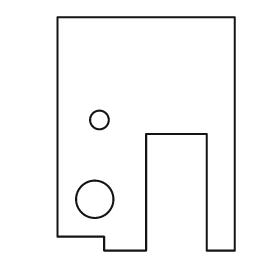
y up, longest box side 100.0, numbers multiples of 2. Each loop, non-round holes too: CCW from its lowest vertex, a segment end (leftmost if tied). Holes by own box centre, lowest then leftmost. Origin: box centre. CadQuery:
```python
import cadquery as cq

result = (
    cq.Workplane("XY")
    .moveTo(-18.0, -50.0)
    .lineTo(0.0, -50.0)
    .lineTo(0.0, 0.0)
    .lineTo(26.0, 0.0)
    .lineTo(26.0, -50.0)
    .lineTo(38.0, -50.0)
    .lineTo(38.0, 50.0)
    .lineTo(-38.0, 50.0)
    .lineTo(-38.0, -44.0)
    .lineTo(-18.0, -44.0)
    .close()
    .moveTo(-22.0, -28.0)
    .circle(8.0)
    .moveTo(-20.0, 6.0)
    .circle(4.0)
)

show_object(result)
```